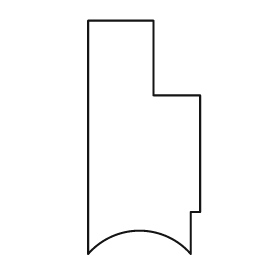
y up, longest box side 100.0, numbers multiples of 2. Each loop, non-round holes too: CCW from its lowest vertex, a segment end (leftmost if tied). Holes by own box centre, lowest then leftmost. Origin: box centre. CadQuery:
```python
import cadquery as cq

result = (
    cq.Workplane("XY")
    .moveTo(-24.0, -50.0)
    .threePointArc((-2.0, -40.0), (20.0, -50.0))
    .lineTo(20.0, -32.0)
    .lineTo(24.0, -32.0)
    .lineTo(24.0, 18.0)
    .lineTo(4.0, 18.0)
    .lineTo(4.0, 50.0)
    .lineTo(-24.0, 50.0)
    .close()
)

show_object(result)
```